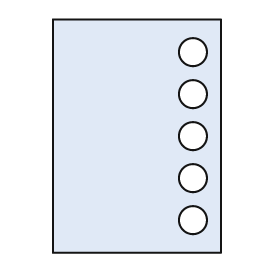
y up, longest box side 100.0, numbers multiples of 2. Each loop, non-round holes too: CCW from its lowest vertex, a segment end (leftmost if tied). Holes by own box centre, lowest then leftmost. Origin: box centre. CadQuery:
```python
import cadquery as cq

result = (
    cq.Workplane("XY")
    .moveTo(-36.0, -50.0)
    .lineTo(36.0, -50.0)
    .lineTo(36.0, 50.0)
    .lineTo(-36.0, 50.0)
    .close()
    .moveTo(24.0, -36.0)
    .circle(6.0)
    .moveTo(24.0, -18.0)
    .circle(6.0)
    .moveTo(24.0, 0.0)
    .circle(6.0)
    .moveTo(24.0, 18.0)
    .circle(6.0)
    .moveTo(24.0, 36.0)
    .circle(6.0)
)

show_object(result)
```